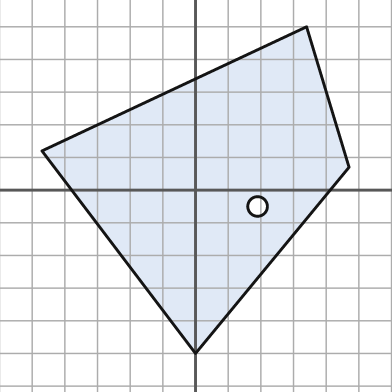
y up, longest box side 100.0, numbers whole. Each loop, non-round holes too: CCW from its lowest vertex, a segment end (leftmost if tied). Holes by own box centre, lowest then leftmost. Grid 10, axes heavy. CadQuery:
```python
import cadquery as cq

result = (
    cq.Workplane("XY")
    .moveTo(0.0, -50.0)
    .lineTo(47.0, 7.0)
    .lineTo(34.0, 50.0)
    .lineTo(-47.0, 12.0)
    .close()
    .moveTo(19.0, -5.0)
    .circle(3.0)
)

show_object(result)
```